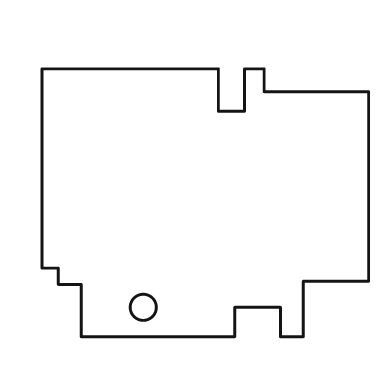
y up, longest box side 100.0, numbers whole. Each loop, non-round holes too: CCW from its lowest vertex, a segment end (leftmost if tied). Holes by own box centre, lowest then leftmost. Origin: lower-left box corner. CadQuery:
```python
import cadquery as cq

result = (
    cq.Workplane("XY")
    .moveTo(12.0, 0.0)
    .lineTo(59.0, 0.0)
    .lineTo(59.0, 9.0)
    .lineTo(73.0, 9.0)
    .lineTo(73.0, 0.0)
    .lineTo(80.0, 0.0)
    .lineTo(80.0, 17.0)
    .lineTo(100.0, 17.0)
    .lineTo(100.0, 75.0)
    .lineTo(68.0, 75.0)
    .lineTo(68.0, 82.0)
    .lineTo(62.0, 82.0)
    .lineTo(62.0, 69.0)
    .lineTo(54.0, 69.0)
    .lineTo(54.0, 82.0)
    .lineTo(0.0, 82.0)
    .lineTo(0.0, 21.0)
    .lineTo(5.0, 21.0)
    .lineTo(5.0, 16.0)
    .lineTo(12.0, 16.0)
    .close()
    .moveTo(31.0, 9.0)
    .circle(4.0)
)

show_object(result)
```